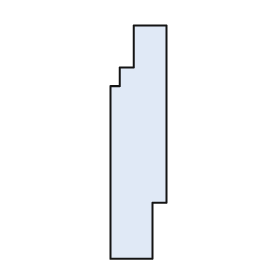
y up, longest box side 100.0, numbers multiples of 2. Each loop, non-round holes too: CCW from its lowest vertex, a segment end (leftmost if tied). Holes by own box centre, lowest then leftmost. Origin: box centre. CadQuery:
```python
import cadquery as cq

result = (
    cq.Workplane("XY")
    .moveTo(-12.0, -50.0)
    .lineTo(6.0, -50.0)
    .lineTo(6.0, -26.0)
    .lineTo(12.0, -26.0)
    .lineTo(12.0, 50.0)
    .lineTo(-2.0, 50.0)
    .lineTo(-2.0, 32.0)
    .lineTo(-8.0, 32.0)
    .lineTo(-8.0, 24.0)
    .lineTo(-12.0, 24.0)
    .close()
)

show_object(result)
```